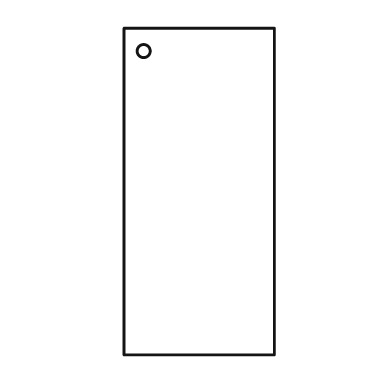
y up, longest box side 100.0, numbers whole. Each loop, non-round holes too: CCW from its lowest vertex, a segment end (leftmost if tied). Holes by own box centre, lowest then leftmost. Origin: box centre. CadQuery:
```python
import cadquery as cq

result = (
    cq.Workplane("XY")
    .moveTo(-23.0, -50.0)
    .lineTo(23.0, -50.0)
    .lineTo(23.0, 50.0)
    .lineTo(-23.0, 50.0)
    .close()
    .moveTo(-17.0, 43.0)
    .circle(2.0)
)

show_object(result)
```